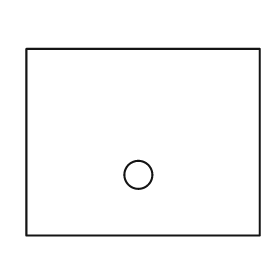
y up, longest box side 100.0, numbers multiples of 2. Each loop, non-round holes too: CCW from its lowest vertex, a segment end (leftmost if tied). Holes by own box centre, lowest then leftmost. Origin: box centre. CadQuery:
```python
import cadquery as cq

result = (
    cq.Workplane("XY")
    .moveTo(-50.0, -40.0)
    .lineTo(50.0, -40.0)
    .lineTo(50.0, 40.0)
    .lineTo(-50.0, 40.0)
    .close()
    .moveTo(-2.0, -14.0)
    .circle(6.0)
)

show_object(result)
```